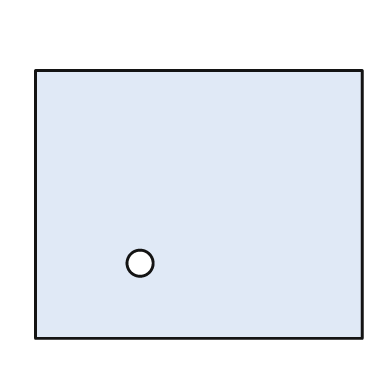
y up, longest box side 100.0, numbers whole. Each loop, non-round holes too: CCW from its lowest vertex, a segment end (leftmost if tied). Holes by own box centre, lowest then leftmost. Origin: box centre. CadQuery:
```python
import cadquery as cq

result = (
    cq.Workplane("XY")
    .moveTo(-50.0, -41.0)
    .lineTo(50.0, -41.0)
    .lineTo(50.0, 41.0)
    .lineTo(-50.0, 41.0)
    .close()
    .moveTo(-18.0, -18.0)
    .circle(4.0)
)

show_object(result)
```